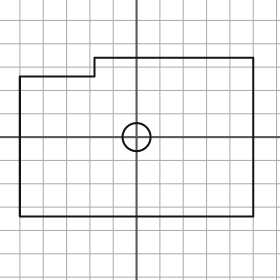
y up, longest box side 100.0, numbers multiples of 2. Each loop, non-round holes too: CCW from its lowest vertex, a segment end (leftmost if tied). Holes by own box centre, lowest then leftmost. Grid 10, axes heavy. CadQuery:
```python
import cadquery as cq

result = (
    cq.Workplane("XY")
    .moveTo(-50.0, -34.0)
    .lineTo(50.0, -34.0)
    .lineTo(50.0, 34.0)
    .lineTo(-18.0, 34.0)
    .lineTo(-18.0, 26.0)
    .lineTo(-50.0, 26.0)
    .close()
    .moveTo(0.0, 0.0)
    .circle(6.0)
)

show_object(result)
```